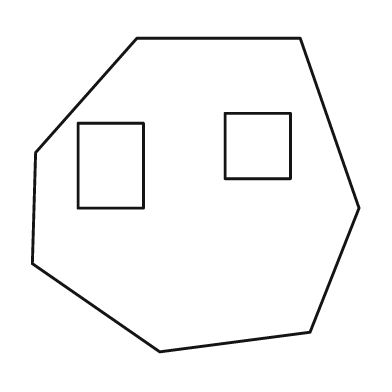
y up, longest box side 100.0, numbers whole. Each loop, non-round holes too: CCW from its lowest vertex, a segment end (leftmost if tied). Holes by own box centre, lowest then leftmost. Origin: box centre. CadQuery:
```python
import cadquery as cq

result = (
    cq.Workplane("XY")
    .moveTo(-11.0, -48.0)
    .lineTo(35.0, -42.0)
    .lineTo(50.0, -4.0)
    .lineTo(32.0, 48.0)
    .lineTo(-18.0, 48.0)
    .lineTo(-49.0, 13.0)
    .lineTo(-50.0, -21.0)
    .close()
    .moveTo(-36.0, -4.0)
    .lineTo(-16.0, -4.0)
    .lineTo(-16.0, 22.0)
    .lineTo(-36.0, 22.0)
    .close()
    .moveTo(9.0, 5.0)
    .lineTo(29.0, 5.0)
    .lineTo(29.0, 25.0)
    .lineTo(9.0, 25.0)
    .close()
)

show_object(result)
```